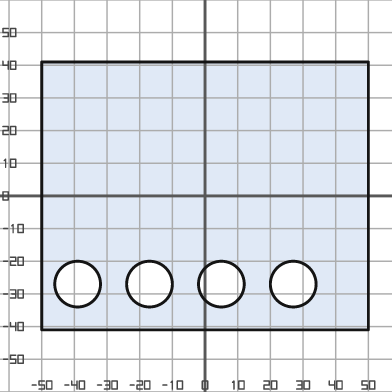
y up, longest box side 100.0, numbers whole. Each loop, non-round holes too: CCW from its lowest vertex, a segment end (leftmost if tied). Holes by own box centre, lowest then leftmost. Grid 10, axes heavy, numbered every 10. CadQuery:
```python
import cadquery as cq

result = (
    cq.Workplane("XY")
    .moveTo(-50.0, -41.0)
    .lineTo(50.0, -41.0)
    .lineTo(50.0, 41.0)
    .lineTo(-50.0, 41.0)
    .close()
    .moveTo(-39.0, -27.0)
    .circle(7.0)
    .moveTo(-17.0, -27.0)
    .circle(7.0)
    .moveTo(5.0, -27.0)
    .circle(7.0)
    .moveTo(27.0, -27.0)
    .circle(7.0)
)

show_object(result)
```